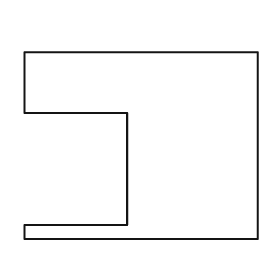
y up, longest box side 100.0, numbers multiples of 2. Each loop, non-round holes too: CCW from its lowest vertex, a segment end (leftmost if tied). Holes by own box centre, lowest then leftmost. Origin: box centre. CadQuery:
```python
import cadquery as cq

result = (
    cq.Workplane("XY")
    .moveTo(-50.0, -40.0)
    .lineTo(50.0, -40.0)
    .lineTo(50.0, 40.0)
    .lineTo(-50.0, 40.0)
    .lineTo(-50.0, 14.0)
    .lineTo(-6.0, 14.0)
    .lineTo(-6.0, -34.0)
    .lineTo(-50.0, -34.0)
    .close()
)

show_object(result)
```